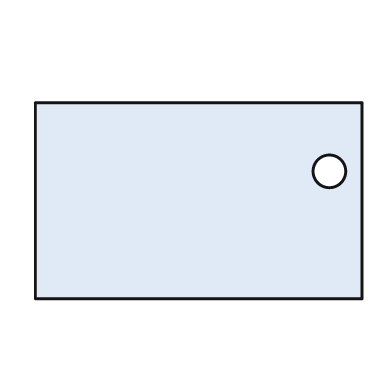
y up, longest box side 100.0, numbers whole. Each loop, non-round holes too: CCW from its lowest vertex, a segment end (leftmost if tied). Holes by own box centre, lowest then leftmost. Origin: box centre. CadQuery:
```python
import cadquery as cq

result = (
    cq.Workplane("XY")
    .moveTo(-50.0, -30.0)
    .lineTo(50.0, -30.0)
    .lineTo(50.0, 30.0)
    .lineTo(-50.0, 30.0)
    .close()
    .moveTo(40.0, 9.0)
    .circle(5.0)
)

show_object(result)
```